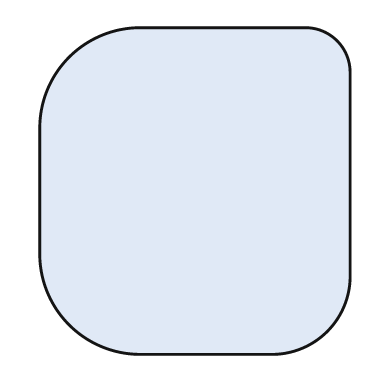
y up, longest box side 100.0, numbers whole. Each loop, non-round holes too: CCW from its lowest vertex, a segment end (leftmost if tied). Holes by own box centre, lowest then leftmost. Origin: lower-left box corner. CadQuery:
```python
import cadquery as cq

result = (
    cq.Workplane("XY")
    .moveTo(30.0, 0.0)
    .lineTo(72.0, 0.0)
    .threePointArc((88.0, 7.0), (95.0, 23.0))
    .lineTo(95.0, 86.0)
    .threePointArc((91.0, 96.0), (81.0, 100.0))
    .lineTo(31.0, 100.0)
    .threePointArc((9.0, 91.0), (0.0, 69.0))
    .lineTo(0.0, 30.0)
    .threePointArc((9.0, 9.0), (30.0, 0.0))
    .close()
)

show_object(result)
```